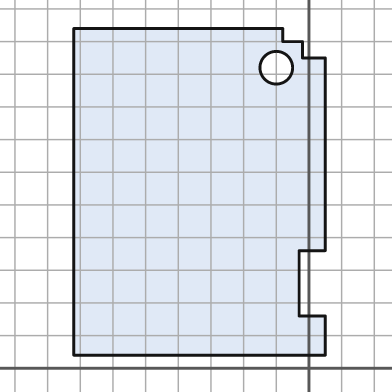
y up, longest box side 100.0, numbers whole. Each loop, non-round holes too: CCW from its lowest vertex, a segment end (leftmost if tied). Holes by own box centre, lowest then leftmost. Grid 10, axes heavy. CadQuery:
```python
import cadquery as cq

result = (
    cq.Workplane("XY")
    .moveTo(-72.0, 4.0)
    .lineTo(5.0, 4.0)
    .lineTo(5.0, 16.0)
    .lineTo(-3.0, 16.0)
    .lineTo(-3.0, 36.0)
    .lineTo(5.0, 36.0)
    .lineTo(5.0, 95.0)
    .lineTo(-2.0, 95.0)
    .lineTo(-2.0, 100.0)
    .lineTo(-8.0, 100.0)
    .lineTo(-8.0, 104.0)
    .lineTo(-72.0, 104.0)
    .close()
    .moveTo(-10.0, 92.0)
    .circle(5.0)
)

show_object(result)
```